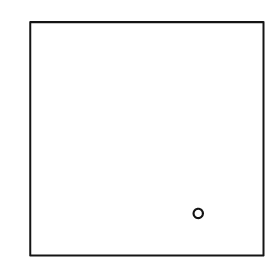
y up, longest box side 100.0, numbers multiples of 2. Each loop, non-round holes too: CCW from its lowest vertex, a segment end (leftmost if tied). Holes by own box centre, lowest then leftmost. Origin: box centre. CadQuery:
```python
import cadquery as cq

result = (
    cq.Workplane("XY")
    .moveTo(-50.0, -50.0)
    .lineTo(50.0, -50.0)
    .lineTo(50.0, 50.0)
    .lineTo(-50.0, 50.0)
    .close()
    .moveTo(22.0, -32.0)
    .circle(2.0)
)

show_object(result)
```